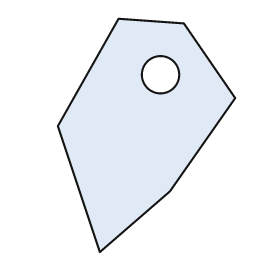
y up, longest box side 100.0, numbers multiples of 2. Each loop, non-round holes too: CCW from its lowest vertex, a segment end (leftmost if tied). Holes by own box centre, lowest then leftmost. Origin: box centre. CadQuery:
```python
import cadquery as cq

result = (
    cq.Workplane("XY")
    .moveTo(-20.0, -50.0)
    .lineTo(10.0, -24.0)
    .lineTo(38.0, 16.0)
    .lineTo(16.0, 48.0)
    .lineTo(-12.0, 50.0)
    .lineTo(-38.0, 4.0)
    .close()
    .moveTo(6.0, 26.0)
    .circle(8.0)
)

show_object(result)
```